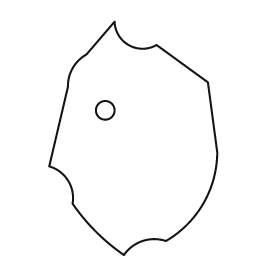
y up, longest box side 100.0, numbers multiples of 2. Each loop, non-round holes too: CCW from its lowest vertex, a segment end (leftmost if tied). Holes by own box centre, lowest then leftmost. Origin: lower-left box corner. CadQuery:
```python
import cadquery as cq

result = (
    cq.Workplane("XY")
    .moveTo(32.0, 0.0)
    .threePointArc((40.0, 6.0), (50.0, 6.0))
    .threePointArc((66.0, 22.0), (72.0, 44.0))
    .lineTo(68.0, 74.0)
    .lineTo(46.0, 90.0)
    .threePointArc((34.0, 90.0), (28.0, 100.0))
    .lineTo(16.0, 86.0)
    .threePointArc((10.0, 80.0), (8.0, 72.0))
    .lineTo(0.0, 38.0)
    .threePointArc((8.0, 32.0), (10.0, 22.0))
    .threePointArc((20.0, 10.0), (32.0, 0.0))
    .close()
    .moveTo(24.0, 62.0)
    .circle(4.0)
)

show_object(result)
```